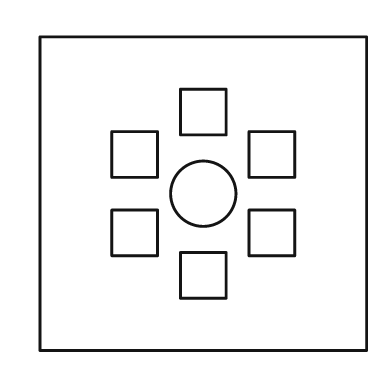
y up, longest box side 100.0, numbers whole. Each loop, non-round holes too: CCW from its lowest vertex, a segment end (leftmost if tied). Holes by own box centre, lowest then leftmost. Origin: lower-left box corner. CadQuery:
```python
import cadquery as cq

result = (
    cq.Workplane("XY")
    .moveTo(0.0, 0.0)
    .lineTo(100.0, 0.0)
    .lineTo(100.0, 96.0)
    .lineTo(0.0, 96.0)
    .close()
    .moveTo(43.0, 16.0)
    .lineTo(57.0, 16.0)
    .lineTo(57.0, 30.0)
    .lineTo(43.0, 30.0)
    .close()
    .moveTo(22.0, 29.0)
    .lineTo(36.0, 29.0)
    .lineTo(36.0, 43.0)
    .lineTo(22.0, 43.0)
    .close()
    .moveTo(64.0, 29.0)
    .lineTo(78.0, 29.0)
    .lineTo(78.0, 43.0)
    .lineTo(64.0, 43.0)
    .close()
    .moveTo(50.0, 48.0)
    .circle(10.0)
    .moveTo(22.0, 53.0)
    .lineTo(36.0, 53.0)
    .lineTo(36.0, 67.0)
    .lineTo(22.0, 67.0)
    .close()
    .moveTo(64.0, 53.0)
    .lineTo(78.0, 53.0)
    .lineTo(78.0, 67.0)
    .lineTo(64.0, 67.0)
    .close()
    .moveTo(43.0, 66.0)
    .lineTo(57.0, 66.0)
    .lineTo(57.0, 80.0)
    .lineTo(43.0, 80.0)
    .close()
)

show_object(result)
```